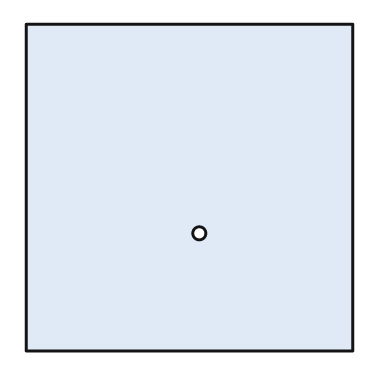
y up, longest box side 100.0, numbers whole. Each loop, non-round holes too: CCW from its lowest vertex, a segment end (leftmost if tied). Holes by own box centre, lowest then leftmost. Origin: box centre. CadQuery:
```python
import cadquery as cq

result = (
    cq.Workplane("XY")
    .moveTo(-50.0, -50.0)
    .lineTo(50.0, -50.0)
    .lineTo(50.0, 50.0)
    .lineTo(-50.0, 50.0)
    .close()
    .moveTo(3.0, -14.0)
    .circle(2.0)
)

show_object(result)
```